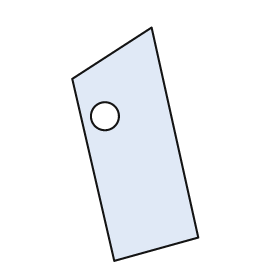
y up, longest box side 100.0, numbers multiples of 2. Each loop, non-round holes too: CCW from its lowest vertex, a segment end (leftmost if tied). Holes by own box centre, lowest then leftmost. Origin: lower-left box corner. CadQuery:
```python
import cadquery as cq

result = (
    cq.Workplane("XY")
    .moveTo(18.0, 0.0)
    .lineTo(54.0, 10.0)
    .lineTo(34.0, 100.0)
    .lineTo(0.0, 78.0)
    .close()
    .moveTo(14.0, 62.0)
    .circle(6.0)
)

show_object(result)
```